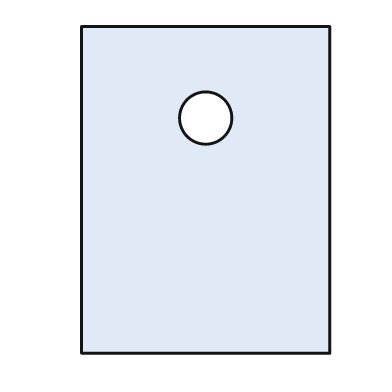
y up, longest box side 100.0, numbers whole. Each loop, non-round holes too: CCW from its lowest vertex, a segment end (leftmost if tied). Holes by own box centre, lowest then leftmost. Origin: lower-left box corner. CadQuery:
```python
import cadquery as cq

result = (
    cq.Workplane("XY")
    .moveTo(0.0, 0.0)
    .lineTo(76.0, 0.0)
    .lineTo(76.0, 100.0)
    .lineTo(0.0, 100.0)
    .close()
    .moveTo(38.0, 72.0)
    .circle(8.0)
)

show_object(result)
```